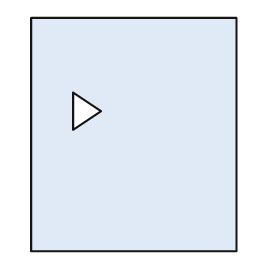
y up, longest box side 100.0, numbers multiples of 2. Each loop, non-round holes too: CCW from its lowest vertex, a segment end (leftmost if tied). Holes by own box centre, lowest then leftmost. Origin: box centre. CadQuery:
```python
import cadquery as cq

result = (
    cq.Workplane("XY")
    .moveTo(-44.0, -50.0)
    .lineTo(44.0, -50.0)
    .lineTo(44.0, 50.0)
    .lineTo(-44.0, 50.0)
    .close()
    .moveTo(-26.0, 2.0)
    .lineTo(-14.0, 10.0)
    .lineTo(-26.0, 18.0)
    .close()
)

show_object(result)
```